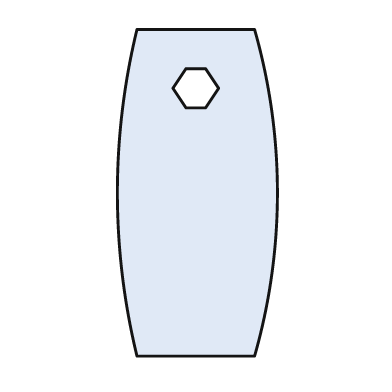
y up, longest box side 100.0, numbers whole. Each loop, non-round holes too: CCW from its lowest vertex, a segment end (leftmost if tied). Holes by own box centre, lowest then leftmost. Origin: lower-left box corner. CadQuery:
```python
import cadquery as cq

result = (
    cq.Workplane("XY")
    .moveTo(6.0, 0.0)
    .lineTo(42.0, 0.0)
    .threePointArc((49.0, 50.0), (42.0, 100.0))
    .lineTo(6.0, 100.0)
    .threePointArc((0.0, 50.0), (6.0, 0.0))
    .close()
    .moveTo(21.0, 76.0)
    .lineTo(27.0, 76.0)
    .lineTo(31.0, 82.0)
    .lineTo(27.0, 88.0)
    .lineTo(21.0, 88.0)
    .lineTo(17.0, 82.0)
    .close()
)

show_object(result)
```